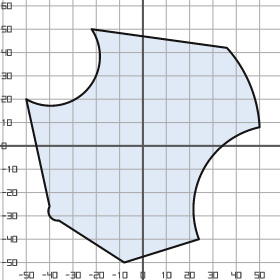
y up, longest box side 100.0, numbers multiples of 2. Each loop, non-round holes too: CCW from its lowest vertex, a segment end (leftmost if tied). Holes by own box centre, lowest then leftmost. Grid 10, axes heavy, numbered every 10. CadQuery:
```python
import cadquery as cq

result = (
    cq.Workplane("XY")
    .moveTo(-8.0, -50.0)
    .lineTo(24.0, -40.0)
    .threePointArc((26.0, -10.0), (50.0, 8.0))
    .threePointArc((46.0, 26.0), (36.0, 42.0))
    .lineTo(-22.0, 50.0)
    .threePointArc((-24.0, 24.0), (-50.0, 20.0))
    .lineTo(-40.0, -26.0)
    .threePointArc((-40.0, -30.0), (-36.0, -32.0))
    .close()
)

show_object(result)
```